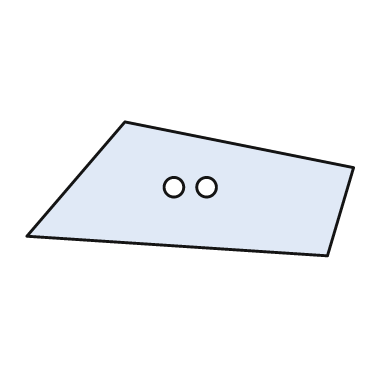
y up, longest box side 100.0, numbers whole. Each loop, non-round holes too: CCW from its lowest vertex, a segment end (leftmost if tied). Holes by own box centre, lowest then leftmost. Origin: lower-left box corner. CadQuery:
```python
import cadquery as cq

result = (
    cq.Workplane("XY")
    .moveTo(92.0, 0.0)
    .lineTo(100.0, 27.0)
    .lineTo(30.0, 41.0)
    .lineTo(0.0, 6.0)
    .close()
    .moveTo(45.0, 21.0)
    .circle(3.0)
    .moveTo(55.0, 21.0)
    .circle(3.0)
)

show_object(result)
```